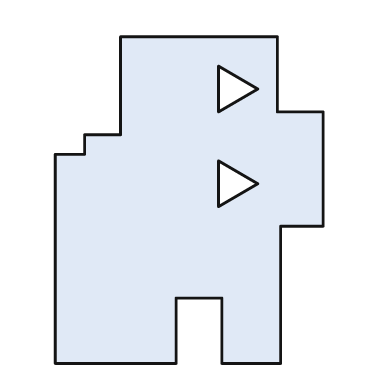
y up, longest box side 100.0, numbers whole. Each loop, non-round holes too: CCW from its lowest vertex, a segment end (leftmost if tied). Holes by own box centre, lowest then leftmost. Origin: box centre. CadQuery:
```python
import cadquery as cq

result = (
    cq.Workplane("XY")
    .moveTo(-41.0, -50.0)
    .lineTo(-4.0, -50.0)
    .lineTo(-4.0, -30.0)
    .lineTo(10.0, -30.0)
    .lineTo(10.0, -50.0)
    .lineTo(28.0, -50.0)
    .lineTo(28.0, -8.0)
    .lineTo(41.0, -8.0)
    .lineTo(41.0, 27.0)
    .lineTo(27.0, 27.0)
    .lineTo(27.0, 50.0)
    .lineTo(-21.0, 50.0)
    .lineTo(-21.0, 20.0)
    .lineTo(-32.0, 20.0)
    .lineTo(-32.0, 14.0)
    .lineTo(-41.0, 14.0)
    .close()
    .moveTo(9.0, -2.0)
    .lineTo(21.0, 5.0)
    .lineTo(9.0, 12.0)
    .close()
    .moveTo(9.0, 27.0)
    .lineTo(21.0, 34.0)
    .lineTo(9.0, 41.0)
    .close()
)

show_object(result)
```